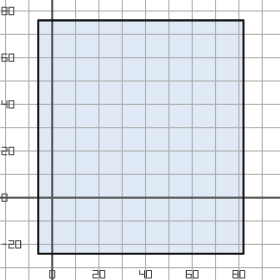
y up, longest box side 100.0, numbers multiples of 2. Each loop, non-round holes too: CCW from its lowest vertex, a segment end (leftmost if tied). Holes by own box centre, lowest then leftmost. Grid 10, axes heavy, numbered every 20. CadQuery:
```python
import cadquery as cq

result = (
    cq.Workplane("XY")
    .moveTo(-6.0, -24.0)
    .lineTo(82.0, -24.0)
    .lineTo(82.0, 76.0)
    .lineTo(-6.0, 76.0)
    .close()
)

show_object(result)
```